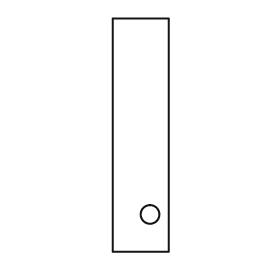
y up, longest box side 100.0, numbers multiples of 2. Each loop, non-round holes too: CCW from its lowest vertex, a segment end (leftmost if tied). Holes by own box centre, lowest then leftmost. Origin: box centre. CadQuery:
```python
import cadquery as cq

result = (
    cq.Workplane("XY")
    .moveTo(-12.0, -50.0)
    .lineTo(12.0, -50.0)
    .lineTo(12.0, 50.0)
    .lineTo(-12.0, 50.0)
    .close()
    .moveTo(4.0, -34.0)
    .circle(4.0)
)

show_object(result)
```